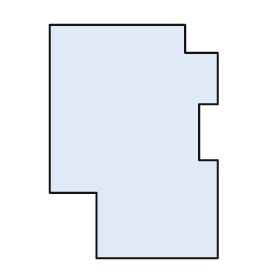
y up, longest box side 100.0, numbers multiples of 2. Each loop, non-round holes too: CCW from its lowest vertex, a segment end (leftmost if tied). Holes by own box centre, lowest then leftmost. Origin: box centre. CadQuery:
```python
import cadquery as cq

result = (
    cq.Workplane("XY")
    .moveTo(-16.0, -50.0)
    .lineTo(36.0, -50.0)
    .lineTo(36.0, -8.0)
    .lineTo(28.0, -8.0)
    .lineTo(28.0, 16.0)
    .lineTo(36.0, 16.0)
    .lineTo(36.0, 38.0)
    .lineTo(22.0, 38.0)
    .lineTo(22.0, 50.0)
    .lineTo(-36.0, 50.0)
    .lineTo(-36.0, -22.0)
    .lineTo(-16.0, -22.0)
    .close()
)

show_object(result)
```